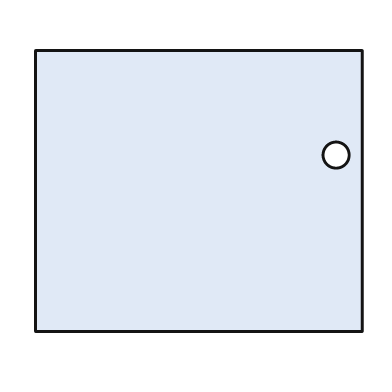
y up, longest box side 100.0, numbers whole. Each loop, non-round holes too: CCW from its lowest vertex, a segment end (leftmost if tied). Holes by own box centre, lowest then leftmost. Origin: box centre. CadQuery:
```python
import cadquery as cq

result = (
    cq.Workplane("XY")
    .moveTo(-50.0, -43.0)
    .lineTo(50.0, -43.0)
    .lineTo(50.0, 43.0)
    .lineTo(-50.0, 43.0)
    .close()
    .moveTo(42.0, 11.0)
    .circle(4.0)
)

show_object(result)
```